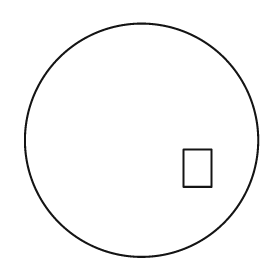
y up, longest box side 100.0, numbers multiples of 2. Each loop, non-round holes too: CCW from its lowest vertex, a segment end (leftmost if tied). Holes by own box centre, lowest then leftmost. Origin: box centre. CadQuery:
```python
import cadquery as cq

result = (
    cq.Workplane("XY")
    .moveTo(0.0, 0.0)
    .circle(50.0)
    .moveTo(18.0, -20.0)
    .lineTo(30.0, -20.0)
    .lineTo(30.0, -4.0)
    .lineTo(18.0, -4.0)
    .close()
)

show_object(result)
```